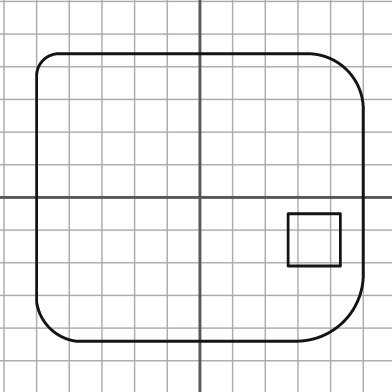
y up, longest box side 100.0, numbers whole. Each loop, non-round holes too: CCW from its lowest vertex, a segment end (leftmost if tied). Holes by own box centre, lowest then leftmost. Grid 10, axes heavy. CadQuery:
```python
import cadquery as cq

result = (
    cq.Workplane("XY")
    .moveTo(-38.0, -44.0)
    .lineTo(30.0, -44.0)
    .threePointArc((44.0, -38.0), (50.0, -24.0))
    .lineTo(50.0, 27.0)
    .threePointArc((45.0, 39.0), (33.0, 44.0))
    .lineTo(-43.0, 44.0)
    .threePointArc((-48.0, 42.0), (-50.0, 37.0))
    .lineTo(-50.0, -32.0)
    .threePointArc((-46.0, -40.0), (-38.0, -44.0))
    .close()
    .moveTo(27.0, -21.0)
    .lineTo(43.0, -21.0)
    .lineTo(43.0, -5.0)
    .lineTo(27.0, -5.0)
    .close()
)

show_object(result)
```